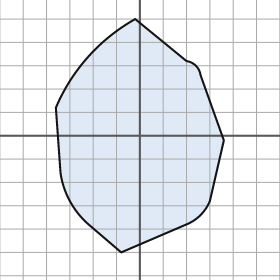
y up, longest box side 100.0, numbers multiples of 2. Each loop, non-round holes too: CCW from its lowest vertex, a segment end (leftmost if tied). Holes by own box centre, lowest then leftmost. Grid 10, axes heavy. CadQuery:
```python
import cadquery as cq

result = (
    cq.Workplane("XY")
    .moveTo(-8.0, -50.0)
    .lineTo(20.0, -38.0)
    .threePointArc((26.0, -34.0), (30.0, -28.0))
    .lineTo(36.0, -2.0)
    .lineTo(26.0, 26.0)
    .threePointArc((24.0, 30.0), (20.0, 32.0))
    .lineTo(-2.0, 50.0)
    .threePointArc((-22.0, 34.0), (-36.0, 12.0))
    .lineTo(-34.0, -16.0)
    .threePointArc((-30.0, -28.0), (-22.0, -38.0))
    .close()
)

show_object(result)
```